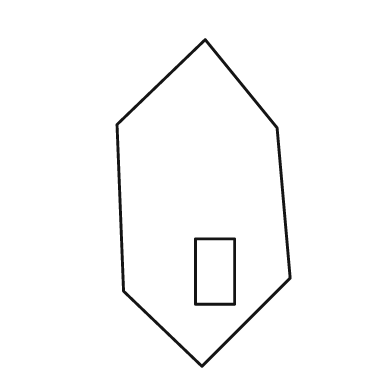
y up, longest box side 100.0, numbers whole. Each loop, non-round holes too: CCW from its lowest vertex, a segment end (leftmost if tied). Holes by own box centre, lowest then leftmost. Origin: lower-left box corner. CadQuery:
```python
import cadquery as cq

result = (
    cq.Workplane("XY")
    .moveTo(26.0, 0.0)
    .lineTo(53.0, 27.0)
    .lineTo(49.0, 73.0)
    .lineTo(27.0, 100.0)
    .lineTo(0.0, 74.0)
    .lineTo(2.0, 23.0)
    .close()
    .moveTo(24.0, 19.0)
    .lineTo(36.0, 19.0)
    .lineTo(36.0, 39.0)
    .lineTo(24.0, 39.0)
    .close()
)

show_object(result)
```